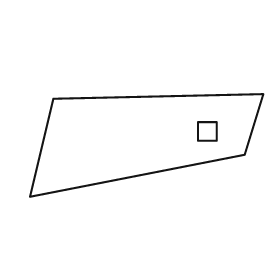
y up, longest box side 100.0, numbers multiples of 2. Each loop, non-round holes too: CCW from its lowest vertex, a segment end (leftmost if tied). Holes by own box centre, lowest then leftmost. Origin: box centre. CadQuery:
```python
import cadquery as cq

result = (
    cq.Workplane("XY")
    .moveTo(-50.0, -22.0)
    .lineTo(42.0, -4.0)
    .lineTo(50.0, 22.0)
    .lineTo(-40.0, 20.0)
    .close()
    .moveTo(22.0, 2.0)
    .lineTo(30.0, 2.0)
    .lineTo(30.0, 10.0)
    .lineTo(22.0, 10.0)
    .close()
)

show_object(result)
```